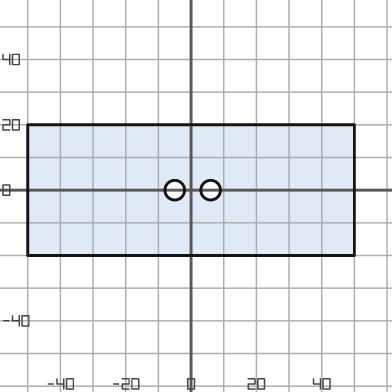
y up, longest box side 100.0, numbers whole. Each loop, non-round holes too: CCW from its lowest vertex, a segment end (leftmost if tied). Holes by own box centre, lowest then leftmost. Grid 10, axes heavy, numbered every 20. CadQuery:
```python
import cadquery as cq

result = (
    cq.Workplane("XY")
    .moveTo(-50.0, -20.0)
    .lineTo(50.0, -20.0)
    .lineTo(50.0, 20.0)
    .lineTo(-50.0, 20.0)
    .close()
    .moveTo(-5.0, 0.0)
    .circle(3.0)
    .moveTo(6.0, 0.0)
    .circle(3.0)
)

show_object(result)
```